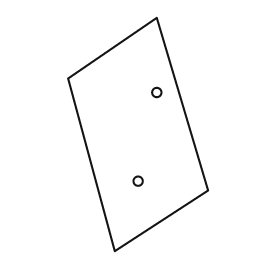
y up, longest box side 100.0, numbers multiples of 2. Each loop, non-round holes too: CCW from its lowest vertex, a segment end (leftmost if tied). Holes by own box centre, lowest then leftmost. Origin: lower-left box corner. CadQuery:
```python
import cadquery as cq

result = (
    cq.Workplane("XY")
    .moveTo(20.0, 0.0)
    .lineTo(60.0, 26.0)
    .lineTo(38.0, 100.0)
    .lineTo(0.0, 74.0)
    .close()
    .moveTo(30.0, 30.0)
    .circle(2.0)
    .moveTo(38.0, 68.0)
    .circle(2.0)
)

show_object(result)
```